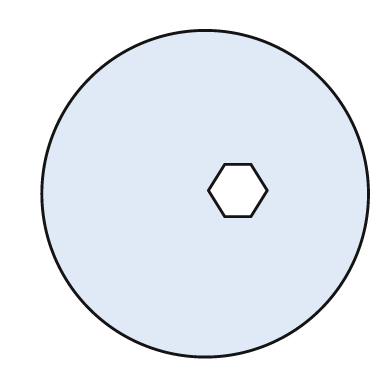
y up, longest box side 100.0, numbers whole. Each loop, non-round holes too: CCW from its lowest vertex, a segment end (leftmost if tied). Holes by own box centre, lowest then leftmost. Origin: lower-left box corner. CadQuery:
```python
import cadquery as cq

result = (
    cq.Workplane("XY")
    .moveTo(50.0, 50.0)
    .circle(50.0)
    .moveTo(56.0, 43.0)
    .lineTo(64.0, 43.0)
    .lineTo(69.0, 51.0)
    .lineTo(64.0, 59.0)
    .lineTo(56.0, 59.0)
    .lineTo(51.0, 51.0)
    .close()
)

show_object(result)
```